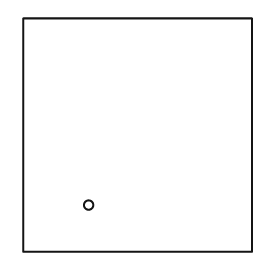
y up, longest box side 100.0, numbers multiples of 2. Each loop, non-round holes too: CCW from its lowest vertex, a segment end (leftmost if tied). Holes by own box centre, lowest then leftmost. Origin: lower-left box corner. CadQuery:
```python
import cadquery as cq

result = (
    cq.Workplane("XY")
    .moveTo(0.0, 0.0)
    .lineTo(98.0, 0.0)
    .lineTo(98.0, 100.0)
    .lineTo(0.0, 100.0)
    .close()
    .moveTo(28.0, 20.0)
    .circle(2.0)
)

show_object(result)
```